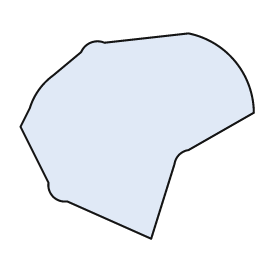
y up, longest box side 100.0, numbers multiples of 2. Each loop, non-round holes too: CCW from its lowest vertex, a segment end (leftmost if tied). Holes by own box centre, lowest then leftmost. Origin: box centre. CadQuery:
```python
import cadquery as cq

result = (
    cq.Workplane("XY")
    .moveTo(6.0, -44.0)
    .lineTo(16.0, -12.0)
    .threePointArc((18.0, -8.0), (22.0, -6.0))
    .lineTo(50.0, 10.0)
    .threePointArc((42.0, 32.0), (22.0, 44.0))
    .lineTo(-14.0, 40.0)
    .threePointArc((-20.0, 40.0), (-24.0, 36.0))
    .lineTo(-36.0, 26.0)
    .threePointArc((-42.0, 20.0), (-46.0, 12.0))
    .lineTo(-50.0, 4.0)
    .lineTo(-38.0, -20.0)
    .threePointArc((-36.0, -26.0), (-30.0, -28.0))
    .close()
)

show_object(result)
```